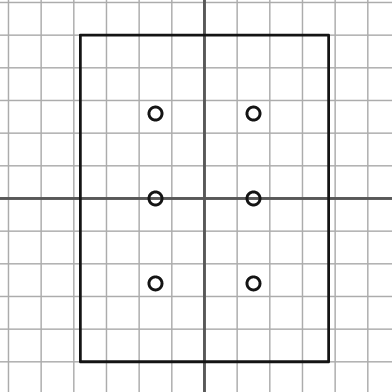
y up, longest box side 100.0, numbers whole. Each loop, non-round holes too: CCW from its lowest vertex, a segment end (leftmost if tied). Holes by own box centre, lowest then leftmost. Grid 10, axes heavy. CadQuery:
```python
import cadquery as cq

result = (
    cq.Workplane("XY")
    .moveTo(-38.0, -50.0)
    .lineTo(38.0, -50.0)
    .lineTo(38.0, 50.0)
    .lineTo(-38.0, 50.0)
    .close()
    .moveTo(-15.0, -26.0)
    .circle(2.0)
    .moveTo(15.0, -26.0)
    .circle(2.0)
    .moveTo(-15.0, 0.0)
    .circle(2.0)
    .moveTo(15.0, 0.0)
    .circle(2.0)
    .moveTo(-15.0, 26.0)
    .circle(2.0)
    .moveTo(15.0, 26.0)
    .circle(2.0)
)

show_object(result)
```